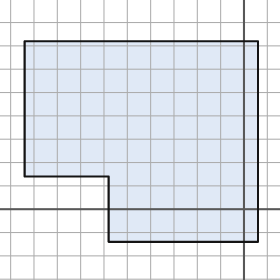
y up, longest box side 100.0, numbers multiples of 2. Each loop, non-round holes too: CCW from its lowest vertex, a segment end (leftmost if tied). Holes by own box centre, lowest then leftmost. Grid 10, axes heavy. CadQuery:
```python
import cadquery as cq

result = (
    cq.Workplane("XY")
    .moveTo(-58.0, -14.0)
    .lineTo(6.0, -14.0)
    .lineTo(6.0, 72.0)
    .lineTo(-94.0, 72.0)
    .lineTo(-94.0, 14.0)
    .lineTo(-58.0, 14.0)
    .close()
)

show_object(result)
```